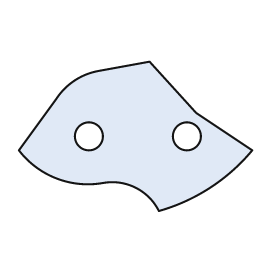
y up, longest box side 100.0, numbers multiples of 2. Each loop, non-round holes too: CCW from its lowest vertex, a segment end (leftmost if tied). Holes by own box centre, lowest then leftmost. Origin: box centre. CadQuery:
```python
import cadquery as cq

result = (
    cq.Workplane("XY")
    .moveTo(10.0, -32.0)
    .threePointArc((32.0, -22.0), (50.0, -6.0))
    .lineTo(26.0, 10.0)
    .lineTo(6.0, 32.0)
    .lineTo(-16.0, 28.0)
    .threePointArc((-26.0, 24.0), (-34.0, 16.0))
    .lineTo(-50.0, -6.0)
    .threePointArc((-34.0, -18.0), (-14.0, -20.0))
    .threePointArc((0.0, -22.0), (10.0, -32.0))
    .close()
    .moveTo(-20.0, 0.0)
    .circle(6.0)
    .moveTo(22.0, 0.0)
    .circle(6.0)
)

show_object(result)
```